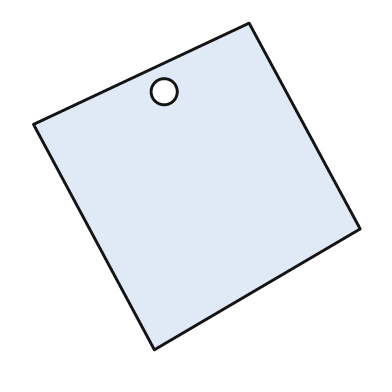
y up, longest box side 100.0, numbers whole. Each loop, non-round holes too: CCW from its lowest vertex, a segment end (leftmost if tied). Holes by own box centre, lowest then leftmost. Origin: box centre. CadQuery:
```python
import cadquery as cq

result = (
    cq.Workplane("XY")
    .moveTo(-13.0, -50.0)
    .lineTo(50.0, -13.0)
    .lineTo(16.0, 50.0)
    .lineTo(-50.0, 19.0)
    .close()
    .moveTo(-10.0, 29.0)
    .circle(4.0)
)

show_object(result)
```